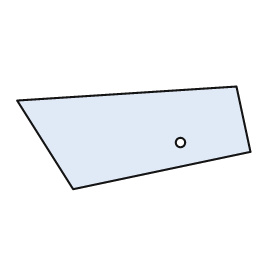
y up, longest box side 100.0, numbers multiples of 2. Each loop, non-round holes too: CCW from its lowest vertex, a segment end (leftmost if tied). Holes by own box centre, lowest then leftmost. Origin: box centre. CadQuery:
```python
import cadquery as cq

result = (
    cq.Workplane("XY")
    .moveTo(-26.0, -22.0)
    .lineTo(50.0, -6.0)
    .lineTo(44.0, 22.0)
    .lineTo(-50.0, 16.0)
    .close()
    .moveTo(20.0, -2.0)
    .circle(2.0)
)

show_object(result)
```